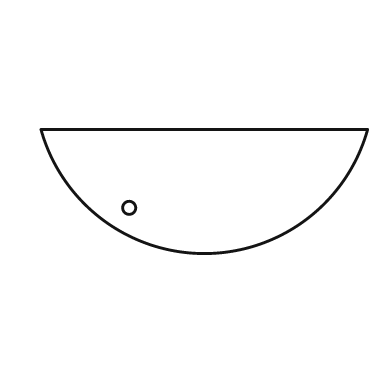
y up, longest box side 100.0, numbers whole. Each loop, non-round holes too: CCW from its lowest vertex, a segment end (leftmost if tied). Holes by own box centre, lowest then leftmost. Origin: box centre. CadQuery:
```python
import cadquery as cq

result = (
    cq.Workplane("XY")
    .moveTo(-50.0, 19.0)
    .threePointArc((0.0, -19.0), (50.0, 19.0))
    .close()
    .moveTo(-23.0, -5.0)
    .circle(2.0)
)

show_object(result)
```